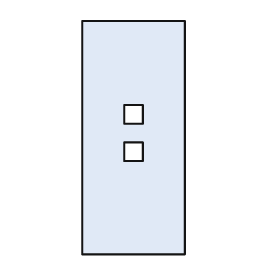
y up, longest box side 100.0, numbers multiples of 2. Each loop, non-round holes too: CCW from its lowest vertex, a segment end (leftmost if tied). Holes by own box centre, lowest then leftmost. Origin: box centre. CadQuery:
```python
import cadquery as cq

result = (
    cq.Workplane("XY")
    .moveTo(-22.0, -50.0)
    .lineTo(22.0, -50.0)
    .lineTo(22.0, 50.0)
    .lineTo(-22.0, 50.0)
    .close()
    .moveTo(-4.0, -10.0)
    .lineTo(4.0, -10.0)
    .lineTo(4.0, -2.0)
    .lineTo(-4.0, -2.0)
    .close()
    .moveTo(-4.0, 6.0)
    .lineTo(4.0, 6.0)
    .lineTo(4.0, 14.0)
    .lineTo(-4.0, 14.0)
    .close()
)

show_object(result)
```